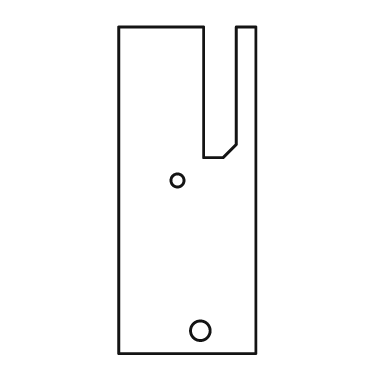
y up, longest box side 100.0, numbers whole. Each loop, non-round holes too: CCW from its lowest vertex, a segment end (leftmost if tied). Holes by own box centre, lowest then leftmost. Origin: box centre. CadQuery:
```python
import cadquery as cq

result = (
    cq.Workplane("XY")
    .moveTo(-21.0, -50.0)
    .lineTo(21.0, -50.0)
    .lineTo(21.0, 50.0)
    .lineTo(15.0, 50.0)
    .lineTo(15.0, 14.0)
    .lineTo(11.0, 10.0)
    .lineTo(5.0, 10.0)
    .lineTo(5.0, 50.0)
    .lineTo(-21.0, 50.0)
    .close()
    .moveTo(4.0, -43.0)
    .circle(3.0)
    .moveTo(-3.0, 3.0)
    .circle(2.0)
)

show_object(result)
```